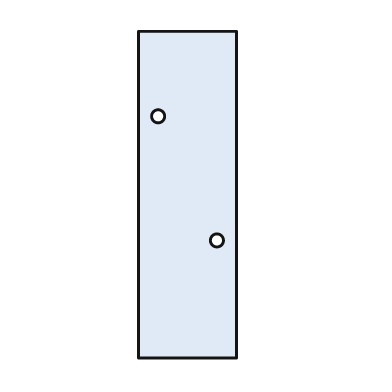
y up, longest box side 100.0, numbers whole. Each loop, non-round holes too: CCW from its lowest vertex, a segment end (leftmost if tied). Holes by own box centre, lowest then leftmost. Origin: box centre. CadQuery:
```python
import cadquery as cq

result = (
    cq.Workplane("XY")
    .moveTo(-15.0, -50.0)
    .lineTo(15.0, -50.0)
    .lineTo(15.0, 50.0)
    .lineTo(-15.0, 50.0)
    .close()
    .moveTo(9.0, -14.0)
    .circle(2.0)
    .moveTo(-9.0, 24.0)
    .circle(2.0)
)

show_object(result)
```